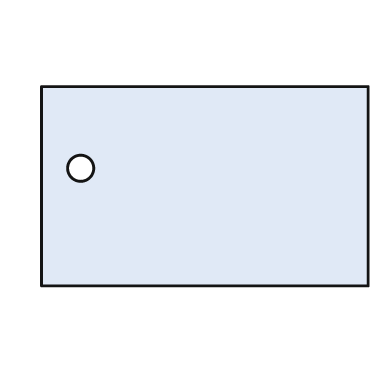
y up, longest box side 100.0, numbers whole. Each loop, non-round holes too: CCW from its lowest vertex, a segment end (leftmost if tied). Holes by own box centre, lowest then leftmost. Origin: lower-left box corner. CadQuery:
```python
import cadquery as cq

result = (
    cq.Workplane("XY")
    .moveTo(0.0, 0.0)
    .lineTo(100.0, 0.0)
    .lineTo(100.0, 61.0)
    .lineTo(0.0, 61.0)
    .close()
    .moveTo(12.0, 36.0)
    .circle(4.0)
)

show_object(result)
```